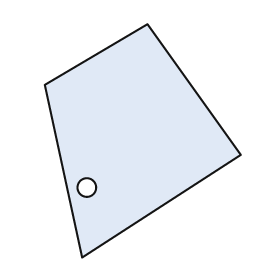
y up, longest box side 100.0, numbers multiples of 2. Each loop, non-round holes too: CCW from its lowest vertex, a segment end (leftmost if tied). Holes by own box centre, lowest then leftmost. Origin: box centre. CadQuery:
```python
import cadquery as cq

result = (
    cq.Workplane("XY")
    .moveTo(-26.0, -50.0)
    .lineTo(42.0, -6.0)
    .lineTo(2.0, 50.0)
    .lineTo(-42.0, 24.0)
    .close()
    .moveTo(-24.0, -20.0)
    .circle(4.0)
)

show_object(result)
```